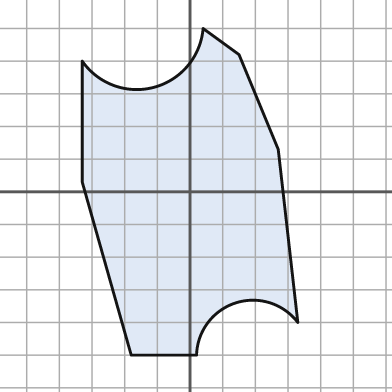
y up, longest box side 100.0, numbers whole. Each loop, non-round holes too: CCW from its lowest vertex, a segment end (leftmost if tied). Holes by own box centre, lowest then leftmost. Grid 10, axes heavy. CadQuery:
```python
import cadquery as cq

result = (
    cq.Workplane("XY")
    .moveTo(-18.0, -50.0)
    .lineTo(2.0, -50.0)
    .threePointArc((14.0, -34.0), (33.0, -40.0))
    .lineTo(27.0, 13.0)
    .lineTo(15.0, 42.0)
    .lineTo(4.0, 50.0)
    .threePointArc((-11.0, 32.0), (-33.0, 40.0))
    .lineTo(-33.0, 3.0)
    .close()
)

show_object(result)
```